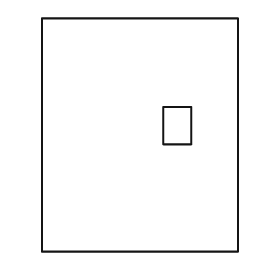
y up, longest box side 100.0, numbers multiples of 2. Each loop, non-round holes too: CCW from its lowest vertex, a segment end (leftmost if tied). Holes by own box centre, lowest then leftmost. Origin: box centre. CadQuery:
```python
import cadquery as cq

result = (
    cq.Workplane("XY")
    .moveTo(-42.0, -50.0)
    .lineTo(42.0, -50.0)
    .lineTo(42.0, 50.0)
    .lineTo(-42.0, 50.0)
    .close()
    .moveTo(10.0, -4.0)
    .lineTo(22.0, -4.0)
    .lineTo(22.0, 12.0)
    .lineTo(10.0, 12.0)
    .close()
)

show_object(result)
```